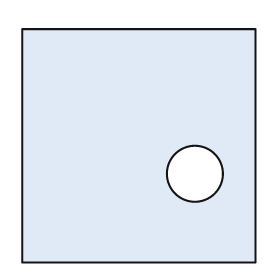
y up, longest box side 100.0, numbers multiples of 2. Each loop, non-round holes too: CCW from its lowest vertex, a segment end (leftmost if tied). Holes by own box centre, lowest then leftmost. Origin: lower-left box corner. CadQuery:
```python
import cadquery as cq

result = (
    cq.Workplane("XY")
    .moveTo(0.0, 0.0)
    .lineTo(100.0, 0.0)
    .lineTo(100.0, 100.0)
    .lineTo(0.0, 100.0)
    .close()
    .moveTo(74.0, 38.0)
    .circle(12.0)
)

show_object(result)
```